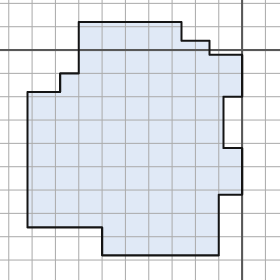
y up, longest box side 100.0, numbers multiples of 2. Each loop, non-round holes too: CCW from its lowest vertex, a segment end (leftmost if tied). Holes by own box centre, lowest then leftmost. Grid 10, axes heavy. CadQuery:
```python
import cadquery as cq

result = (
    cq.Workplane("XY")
    .moveTo(-60.0, -88.0)
    .lineTo(-10.0, -88.0)
    .lineTo(-10.0, -62.0)
    .lineTo(0.0, -62.0)
    .lineTo(0.0, -42.0)
    .lineTo(-8.0, -42.0)
    .lineTo(-8.0, -20.0)
    .lineTo(0.0, -20.0)
    .lineTo(0.0, -2.0)
    .lineTo(-14.0, -2.0)
    .lineTo(-14.0, 4.0)
    .lineTo(-26.0, 4.0)
    .lineTo(-26.0, 12.0)
    .lineTo(-70.0, 12.0)
    .lineTo(-70.0, -10.0)
    .lineTo(-78.0, -10.0)
    .lineTo(-78.0, -18.0)
    .lineTo(-92.0, -18.0)
    .lineTo(-92.0, -76.0)
    .lineTo(-60.0, -76.0)
    .close()
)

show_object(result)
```